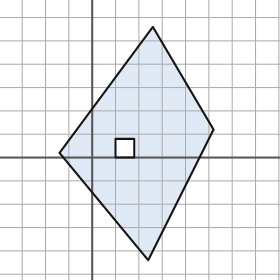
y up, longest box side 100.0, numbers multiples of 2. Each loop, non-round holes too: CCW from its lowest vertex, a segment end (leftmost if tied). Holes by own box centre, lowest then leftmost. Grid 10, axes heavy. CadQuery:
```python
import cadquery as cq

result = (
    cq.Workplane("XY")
    .moveTo(24.0, -44.0)
    .lineTo(52.0, 12.0)
    .lineTo(26.0, 56.0)
    .lineTo(-14.0, 2.0)
    .close()
    .moveTo(10.0, 0.0)
    .lineTo(18.0, 0.0)
    .lineTo(18.0, 8.0)
    .lineTo(10.0, 8.0)
    .close()
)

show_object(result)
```